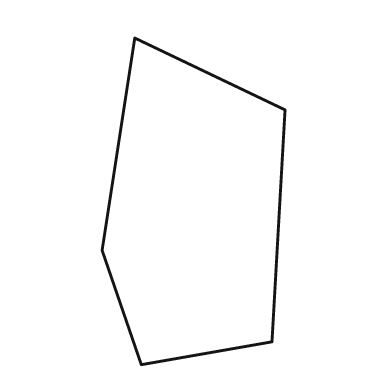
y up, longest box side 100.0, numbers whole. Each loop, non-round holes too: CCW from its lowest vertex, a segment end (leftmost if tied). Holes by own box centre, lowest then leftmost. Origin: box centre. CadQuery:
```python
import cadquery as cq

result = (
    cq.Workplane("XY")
    .moveTo(-16.0, -50.0)
    .lineTo(24.0, -43.0)
    .lineTo(28.0, 28.0)
    .lineTo(-18.0, 50.0)
    .lineTo(-28.0, -15.0)
    .close()
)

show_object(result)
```